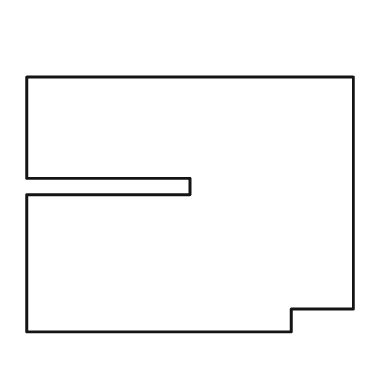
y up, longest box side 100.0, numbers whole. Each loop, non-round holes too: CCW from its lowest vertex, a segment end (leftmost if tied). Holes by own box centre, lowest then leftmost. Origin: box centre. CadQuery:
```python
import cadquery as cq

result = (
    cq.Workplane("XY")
    .moveTo(-50.0, -39.0)
    .lineTo(31.0, -39.0)
    .lineTo(31.0, -32.0)
    .lineTo(50.0, -32.0)
    .lineTo(50.0, 39.0)
    .lineTo(-50.0, 39.0)
    .lineTo(-50.0, 8.0)
    .lineTo(0.0, 8.0)
    .lineTo(0.0, 3.0)
    .lineTo(-50.0, 3.0)
    .close()
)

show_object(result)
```